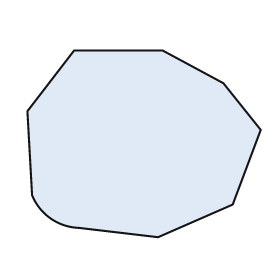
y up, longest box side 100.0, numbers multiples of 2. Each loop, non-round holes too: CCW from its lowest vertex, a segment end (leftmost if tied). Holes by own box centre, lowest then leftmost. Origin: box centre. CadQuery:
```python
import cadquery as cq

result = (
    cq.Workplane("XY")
    .moveTo(6.0, -40.0)
    .lineTo(38.0, -26.0)
    .lineTo(50.0, 6.0)
    .lineTo(34.0, 26.0)
    .lineTo(8.0, 40.0)
    .lineTo(-30.0, 40.0)
    .lineTo(-50.0, 14.0)
    .lineTo(-48.0, -22.0)
    .threePointArc((-40.0, -32.0), (-28.0, -36.0))
    .close()
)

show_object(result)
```